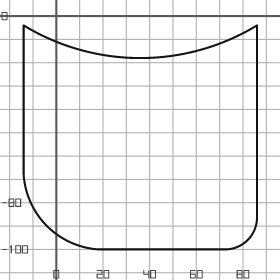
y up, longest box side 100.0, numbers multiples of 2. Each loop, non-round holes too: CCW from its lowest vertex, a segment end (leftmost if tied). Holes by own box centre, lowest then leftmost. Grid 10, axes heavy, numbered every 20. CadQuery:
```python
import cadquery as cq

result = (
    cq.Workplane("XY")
    .moveTo(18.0, -100.0)
    .lineTo(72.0, -100.0)
    .threePointArc((82.0, -96.0), (86.0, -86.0))
    .lineTo(86.0, -4.0)
    .threePointArc((36.0, -18.0), (-14.0, -4.0))
    .lineTo(-14.0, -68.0)
    .threePointArc((-4.0, -90.0), (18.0, -100.0))
    .close()
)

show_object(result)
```